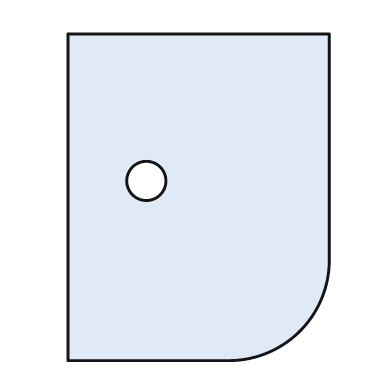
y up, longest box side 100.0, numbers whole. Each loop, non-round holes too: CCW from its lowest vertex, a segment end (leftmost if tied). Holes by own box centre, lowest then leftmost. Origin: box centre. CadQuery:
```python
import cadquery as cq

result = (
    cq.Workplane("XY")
    .moveTo(-40.0, -50.0)
    .lineTo(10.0, -50.0)
    .threePointArc((31.0, -41.0), (40.0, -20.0))
    .lineTo(40.0, 50.0)
    .lineTo(-40.0, 50.0)
    .close()
    .moveTo(-16.0, 5.0)
    .circle(6.0)
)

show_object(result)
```